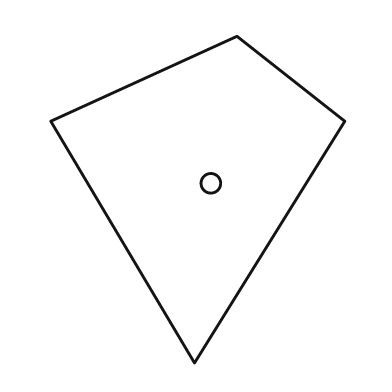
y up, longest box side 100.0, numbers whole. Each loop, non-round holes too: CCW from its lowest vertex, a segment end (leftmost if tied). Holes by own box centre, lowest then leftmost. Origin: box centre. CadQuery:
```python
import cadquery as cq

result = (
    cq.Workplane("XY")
    .moveTo(-1.0, -50.0)
    .lineTo(45.0, 24.0)
    .lineTo(12.0, 50.0)
    .lineTo(-45.0, 24.0)
    .close()
    .moveTo(4.0, 5.0)
    .circle(3.0)
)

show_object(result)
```